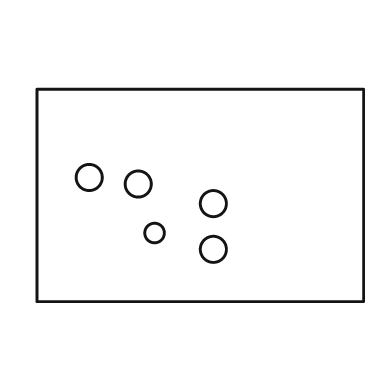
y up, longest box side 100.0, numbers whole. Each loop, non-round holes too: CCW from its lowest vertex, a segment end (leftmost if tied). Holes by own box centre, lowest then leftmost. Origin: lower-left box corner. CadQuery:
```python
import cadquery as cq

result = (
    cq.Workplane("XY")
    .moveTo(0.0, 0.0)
    .lineTo(100.0, 0.0)
    .lineTo(100.0, 65.0)
    .lineTo(0.0, 65.0)
    .close()
    .moveTo(54.0, 16.0)
    .circle(4.0)
    .moveTo(36.0, 21.0)
    .circle(3.0)
    .moveTo(54.0, 30.0)
    .circle(4.0)
    .moveTo(31.0, 36.0)
    .circle(4.0)
    .moveTo(16.0, 38.0)
    .circle(4.0)
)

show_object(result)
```